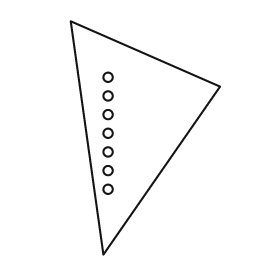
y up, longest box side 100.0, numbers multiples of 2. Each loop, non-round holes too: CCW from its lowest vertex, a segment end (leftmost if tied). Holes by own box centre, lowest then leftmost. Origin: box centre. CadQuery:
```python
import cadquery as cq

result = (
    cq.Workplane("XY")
    .moveTo(-18.0, -50.0)
    .lineTo(32.0, 22.0)
    .lineTo(-32.0, 50.0)
    .close()
    .moveTo(-16.0, -22.0)
    .circle(2.0)
    .moveTo(-16.0, -14.0)
    .circle(2.0)
    .moveTo(-16.0, -6.0)
    .circle(2.0)
    .moveTo(-16.0, 2.0)
    .circle(2.0)
    .moveTo(-16.0, 10.0)
    .circle(2.0)
    .moveTo(-16.0, 18.0)
    .circle(2.0)
    .moveTo(-16.0, 26.0)
    .circle(2.0)
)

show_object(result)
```